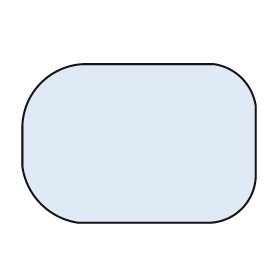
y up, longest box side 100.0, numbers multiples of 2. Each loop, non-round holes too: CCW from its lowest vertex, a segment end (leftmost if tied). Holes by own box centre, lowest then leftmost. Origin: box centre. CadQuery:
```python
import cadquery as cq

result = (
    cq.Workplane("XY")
    .moveTo(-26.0, -34.0)
    .lineTo(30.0, -34.0)
    .threePointArc((44.0, -28.0), (50.0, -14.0))
    .lineTo(50.0, 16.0)
    .threePointArc((44.0, 28.0), (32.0, 34.0))
    .lineTo(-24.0, 34.0)
    .threePointArc((-42.0, 26.0), (-50.0, 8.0))
    .lineTo(-50.0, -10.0)
    .threePointArc((-42.0, -26.0), (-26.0, -34.0))
    .close()
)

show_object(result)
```